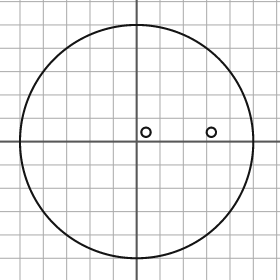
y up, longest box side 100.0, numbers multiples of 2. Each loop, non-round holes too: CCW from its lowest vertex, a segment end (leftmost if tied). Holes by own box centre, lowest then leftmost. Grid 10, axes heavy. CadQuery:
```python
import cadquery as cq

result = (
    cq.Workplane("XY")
    .moveTo(0.0, 0.0)
    .circle(50.0)
    .moveTo(4.0, 4.0)
    .circle(2.0)
    .moveTo(32.0, 4.0)
    .circle(2.0)
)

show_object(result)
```